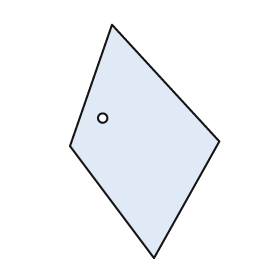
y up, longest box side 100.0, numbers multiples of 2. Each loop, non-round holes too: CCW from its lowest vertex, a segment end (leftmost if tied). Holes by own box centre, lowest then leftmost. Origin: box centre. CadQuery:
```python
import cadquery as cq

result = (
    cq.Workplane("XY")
    .moveTo(4.0, -50.0)
    .lineTo(32.0, 0.0)
    .lineTo(-14.0, 50.0)
    .lineTo(-32.0, -2.0)
    .close()
    .moveTo(-18.0, 10.0)
    .circle(2.0)
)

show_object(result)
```